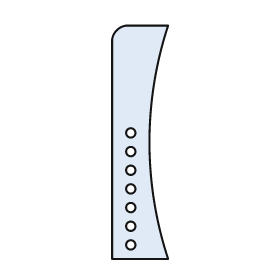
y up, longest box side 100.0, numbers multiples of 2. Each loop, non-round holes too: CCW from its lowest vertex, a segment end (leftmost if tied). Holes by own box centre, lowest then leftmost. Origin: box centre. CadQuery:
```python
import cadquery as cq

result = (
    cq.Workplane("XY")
    .moveTo(-12.0, -50.0)
    .lineTo(12.0, -50.0)
    .threePointArc((4.0, 0.0), (12.0, 50.0))
    .lineTo(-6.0, 50.0)
    .threePointArc((-10.0, 48.0), (-12.0, 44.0))
    .close()
    .moveTo(-4.0, -44.0)
    .circle(2.0)
    .moveTo(-4.0, -36.0)
    .circle(2.0)
    .moveTo(-4.0, -28.0)
    .circle(2.0)
    .moveTo(-4.0, -20.0)
    .circle(2.0)
    .moveTo(-4.0, -12.0)
    .circle(2.0)
    .moveTo(-4.0, -4.0)
    .circle(2.0)
    .moveTo(-4.0, 4.0)
    .circle(2.0)
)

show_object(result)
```